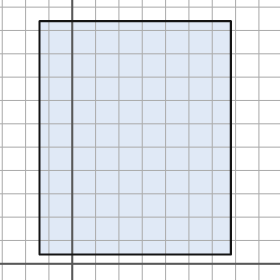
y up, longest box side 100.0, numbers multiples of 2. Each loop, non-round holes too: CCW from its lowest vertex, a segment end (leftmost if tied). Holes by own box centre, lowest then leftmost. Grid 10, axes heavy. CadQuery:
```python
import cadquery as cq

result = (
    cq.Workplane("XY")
    .moveTo(-14.0, 4.0)
    .lineTo(68.0, 4.0)
    .lineTo(68.0, 104.0)
    .lineTo(-14.0, 104.0)
    .close()
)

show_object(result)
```